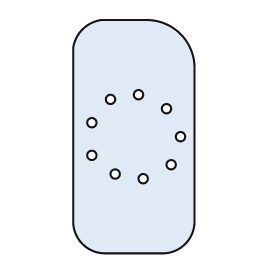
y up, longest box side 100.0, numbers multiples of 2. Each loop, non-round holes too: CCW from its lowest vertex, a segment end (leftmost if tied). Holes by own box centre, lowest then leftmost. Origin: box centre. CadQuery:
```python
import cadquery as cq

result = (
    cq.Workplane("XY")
    .moveTo(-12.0, -50.0)
    .lineTo(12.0, -50.0)
    .threePointArc((22.0, -46.0), (26.0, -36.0))
    .lineTo(26.0, 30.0)
    .threePointArc((20.0, 44.0), (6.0, 50.0))
    .lineTo(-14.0, 50.0)
    .threePointArc((-22.0, 46.0), (-26.0, 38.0))
    .lineTo(-26.0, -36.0)
    .threePointArc((-22.0, -46.0), (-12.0, -50.0))
    .close()
    .moveTo(4.0, -18.0)
    .circle(2.0)
    .moveTo(-8.0, -16.0)
    .circle(2.0)
    .moveTo(16.0, -12.0)
    .circle(2.0)
    .moveTo(-18.0, -8.0)
    .circle(2.0)
    .moveTo(20.0, 0.0)
    .circle(2.0)
    .moveTo(-18.0, 6.0)
    .circle(2.0)
    .moveTo(14.0, 12.0)
    .circle(2.0)
    .moveTo(-10.0, 16.0)
    .circle(2.0)
    .moveTo(2.0, 18.0)
    .circle(2.0)
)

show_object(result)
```